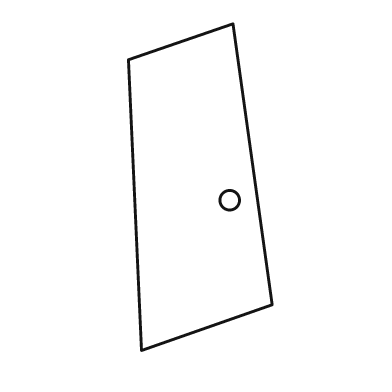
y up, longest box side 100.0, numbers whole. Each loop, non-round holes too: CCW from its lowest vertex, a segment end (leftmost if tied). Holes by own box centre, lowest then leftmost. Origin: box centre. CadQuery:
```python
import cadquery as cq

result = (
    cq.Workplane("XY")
    .moveTo(-18.0, -50.0)
    .lineTo(22.0, -36.0)
    .lineTo(10.0, 50.0)
    .lineTo(-22.0, 39.0)
    .close()
    .moveTo(9.0, -4.0)
    .circle(3.0)
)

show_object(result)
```